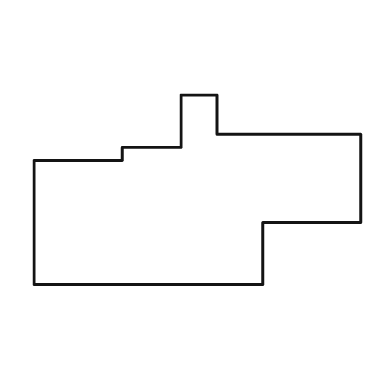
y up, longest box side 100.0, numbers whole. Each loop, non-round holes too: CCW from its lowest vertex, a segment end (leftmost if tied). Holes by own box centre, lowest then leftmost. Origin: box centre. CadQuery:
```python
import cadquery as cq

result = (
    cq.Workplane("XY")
    .moveTo(-50.0, -29.0)
    .lineTo(20.0, -29.0)
    .lineTo(20.0, -10.0)
    .lineTo(50.0, -10.0)
    .lineTo(50.0, 17.0)
    .lineTo(6.0, 17.0)
    .lineTo(6.0, 29.0)
    .lineTo(-5.0, 29.0)
    .lineTo(-5.0, 13.0)
    .lineTo(-23.0, 13.0)
    .lineTo(-23.0, 9.0)
    .lineTo(-50.0, 9.0)
    .close()
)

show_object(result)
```